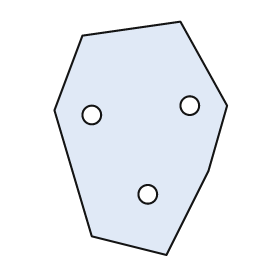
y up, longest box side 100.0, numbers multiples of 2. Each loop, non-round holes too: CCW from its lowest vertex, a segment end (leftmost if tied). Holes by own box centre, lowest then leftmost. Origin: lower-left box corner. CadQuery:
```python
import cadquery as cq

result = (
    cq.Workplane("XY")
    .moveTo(48.0, 0.0)
    .lineTo(66.0, 36.0)
    .lineTo(74.0, 64.0)
    .lineTo(54.0, 100.0)
    .lineTo(12.0, 94.0)
    .lineTo(0.0, 62.0)
    .lineTo(16.0, 8.0)
    .close()
    .moveTo(40.0, 26.0)
    .circle(4.0)
    .moveTo(16.0, 60.0)
    .circle(4.0)
    .moveTo(58.0, 64.0)
    .circle(4.0)
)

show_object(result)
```